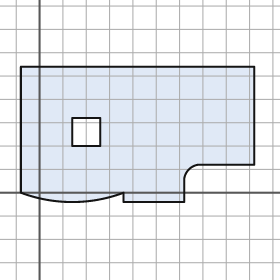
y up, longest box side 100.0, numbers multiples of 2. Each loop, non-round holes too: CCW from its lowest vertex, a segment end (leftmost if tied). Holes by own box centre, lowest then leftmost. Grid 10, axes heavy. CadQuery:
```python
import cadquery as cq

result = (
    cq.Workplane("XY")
    .moveTo(36.0, -4.0)
    .lineTo(62.0, -4.0)
    .lineTo(62.0, 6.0)
    .threePointArc((64.0, 10.0), (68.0, 12.0))
    .lineTo(92.0, 12.0)
    .lineTo(92.0, 54.0)
    .lineTo(-8.0, 54.0)
    .lineTo(-8.0, 0.0)
    .threePointArc((14.0, -4.0), (36.0, 0.0))
    .close()
    .moveTo(14.0, 20.0)
    .lineTo(26.0, 20.0)
    .lineTo(26.0, 32.0)
    .lineTo(14.0, 32.0)
    .close()
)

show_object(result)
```